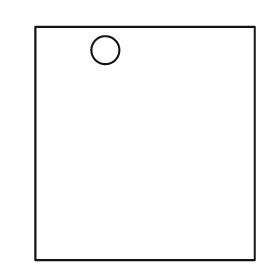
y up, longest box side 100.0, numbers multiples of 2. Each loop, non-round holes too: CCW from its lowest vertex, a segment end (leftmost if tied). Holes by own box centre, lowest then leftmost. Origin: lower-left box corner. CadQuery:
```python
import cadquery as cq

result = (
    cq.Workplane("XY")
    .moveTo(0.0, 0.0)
    .lineTo(94.0, 0.0)
    .lineTo(94.0, 100.0)
    .lineTo(0.0, 100.0)
    .close()
    .moveTo(30.0, 90.0)
    .circle(6.0)
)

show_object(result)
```